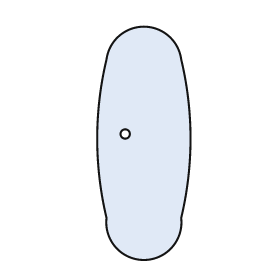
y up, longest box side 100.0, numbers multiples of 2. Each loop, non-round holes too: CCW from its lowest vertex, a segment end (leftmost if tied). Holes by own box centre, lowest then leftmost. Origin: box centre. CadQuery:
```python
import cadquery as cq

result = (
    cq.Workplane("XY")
    .moveTo(-16.0, -32.0)
    .threePointArc((0.0, -50.0), (16.0, -32.0))
    .threePointArc((20.0, 2.0), (16.0, 36.0))
    .threePointArc((0.0, 50.0), (-16.0, 36.0))
    .threePointArc((-20.0, 2.0), (-16.0, -32.0))
    .close()
    .moveTo(-8.0, 4.0)
    .circle(2.0)
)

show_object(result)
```